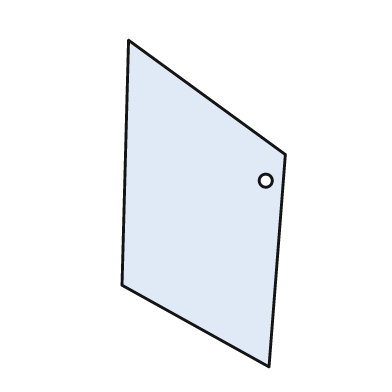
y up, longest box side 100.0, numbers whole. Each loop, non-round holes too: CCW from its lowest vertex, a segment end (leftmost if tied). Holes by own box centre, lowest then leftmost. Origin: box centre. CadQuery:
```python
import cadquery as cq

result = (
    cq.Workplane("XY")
    .moveTo(20.0, -50.0)
    .lineTo(25.0, 15.0)
    .lineTo(-23.0, 50.0)
    .lineTo(-25.0, -25.0)
    .close()
    .moveTo(19.0, 7.0)
    .circle(2.0)
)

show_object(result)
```